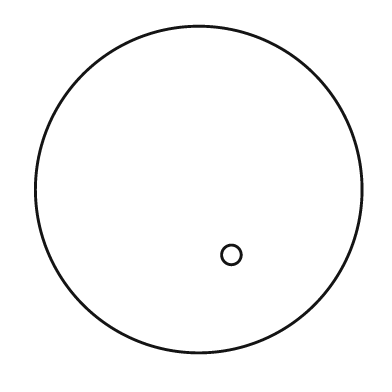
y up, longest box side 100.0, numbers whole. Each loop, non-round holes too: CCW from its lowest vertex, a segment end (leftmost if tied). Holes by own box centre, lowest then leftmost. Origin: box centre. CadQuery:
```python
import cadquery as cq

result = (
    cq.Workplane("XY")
    .moveTo(0.0, 0.0)
    .circle(50.0)
    .moveTo(10.0, -20.0)
    .circle(3.0)
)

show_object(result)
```